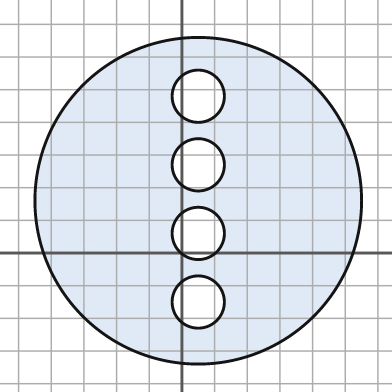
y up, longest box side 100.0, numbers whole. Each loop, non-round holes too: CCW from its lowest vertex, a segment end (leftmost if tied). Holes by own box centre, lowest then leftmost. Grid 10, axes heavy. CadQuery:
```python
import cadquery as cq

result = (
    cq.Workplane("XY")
    .moveTo(5.0, 16.0)
    .circle(50.0)
    .moveTo(5.0, -15.0)
    .circle(8.0)
    .moveTo(5.0, 6.0)
    .circle(8.0)
    .moveTo(5.0, 27.0)
    .circle(8.0)
    .moveTo(5.0, 48.0)
    .circle(8.0)
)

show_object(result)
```